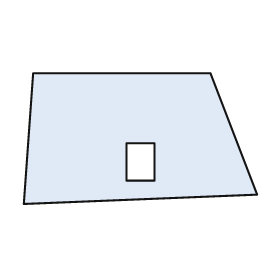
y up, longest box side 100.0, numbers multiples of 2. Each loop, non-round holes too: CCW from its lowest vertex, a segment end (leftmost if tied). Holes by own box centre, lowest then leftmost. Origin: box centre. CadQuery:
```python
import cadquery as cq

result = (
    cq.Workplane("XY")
    .moveTo(-50.0, -28.0)
    .lineTo(50.0, -24.0)
    .lineTo(30.0, 28.0)
    .lineTo(-46.0, 28.0)
    .close()
    .moveTo(-6.0, -18.0)
    .lineTo(6.0, -18.0)
    .lineTo(6.0, -2.0)
    .lineTo(-6.0, -2.0)
    .close()
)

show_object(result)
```